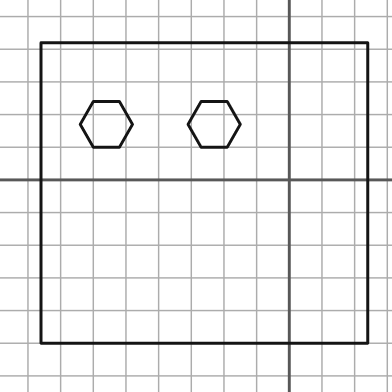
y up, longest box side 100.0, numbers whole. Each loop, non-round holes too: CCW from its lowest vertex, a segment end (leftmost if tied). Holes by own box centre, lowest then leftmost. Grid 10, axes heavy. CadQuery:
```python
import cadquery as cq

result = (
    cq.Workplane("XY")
    .moveTo(-76.0, -50.0)
    .lineTo(24.0, -50.0)
    .lineTo(24.0, 42.0)
    .lineTo(-76.0, 42.0)
    .close()
    .moveTo(-60.0, 10.0)
    .lineTo(-52.0, 10.0)
    .lineTo(-48.0, 17.0)
    .lineTo(-52.0, 24.0)
    .lineTo(-60.0, 24.0)
    .lineTo(-64.0, 17.0)
    .close()
    .moveTo(-27.0, 10.0)
    .lineTo(-19.0, 10.0)
    .lineTo(-15.0, 17.0)
    .lineTo(-19.0, 24.0)
    .lineTo(-27.0, 24.0)
    .lineTo(-31.0, 17.0)
    .close()
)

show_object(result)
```